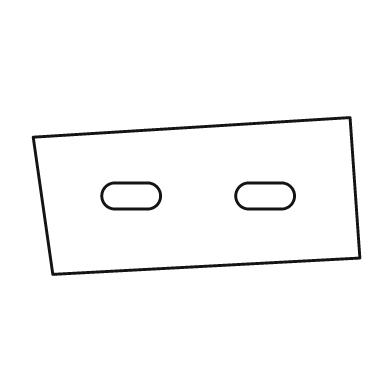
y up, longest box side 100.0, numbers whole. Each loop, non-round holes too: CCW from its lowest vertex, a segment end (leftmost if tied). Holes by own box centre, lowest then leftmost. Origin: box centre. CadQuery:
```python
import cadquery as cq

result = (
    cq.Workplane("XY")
    .moveTo(-44.0, -24.0)
    .lineTo(50.0, -19.0)
    .lineTo(47.0, 24.0)
    .lineTo(-50.0, 18.0)
    .close()
    .moveTo(-25.0, -4.0)
    .lineTo(-15.0, -4.0)
    .threePointArc((-11.0, 0.0), (-15.0, 4.0))
    .lineTo(-25.0, 4.0)
    .threePointArc((-29.0, 0.0), (-25.0, -4.0))
    .close()
    .moveTo(16.0, -4.0)
    .lineTo(26.0, -4.0)
    .threePointArc((30.0, 0.0), (26.0, 4.0))
    .lineTo(16.0, 4.0)
    .threePointArc((12.0, 0.0), (16.0, -4.0))
    .close()
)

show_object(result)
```